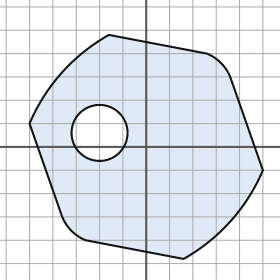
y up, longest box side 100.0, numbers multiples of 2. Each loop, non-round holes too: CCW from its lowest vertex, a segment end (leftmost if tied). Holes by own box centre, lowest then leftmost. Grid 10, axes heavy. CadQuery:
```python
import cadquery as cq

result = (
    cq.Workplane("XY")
    .moveTo(16.0, -48.0)
    .threePointArc((36.0, -32.0), (50.0, -10.0))
    .lineTo(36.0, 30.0)
    .threePointArc((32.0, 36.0), (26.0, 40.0))
    .lineTo(-16.0, 48.0)
    .threePointArc((-36.0, 32.0), (-50.0, 10.0))
    .lineTo(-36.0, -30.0)
    .threePointArc((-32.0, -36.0), (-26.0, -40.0))
    .close()
    .moveTo(-20.0, 6.0)
    .circle(12.0)
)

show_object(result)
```